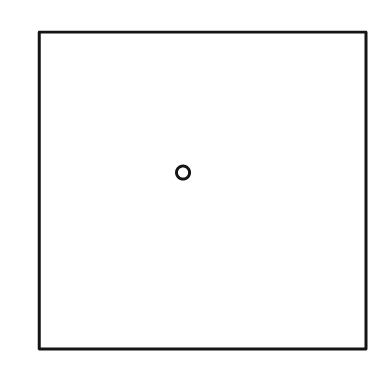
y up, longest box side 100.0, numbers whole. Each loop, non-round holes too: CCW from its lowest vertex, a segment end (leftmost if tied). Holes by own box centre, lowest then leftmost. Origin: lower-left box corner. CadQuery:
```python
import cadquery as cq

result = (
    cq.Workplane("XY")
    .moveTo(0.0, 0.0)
    .lineTo(100.0, 0.0)
    .lineTo(100.0, 97.0)
    .lineTo(0.0, 97.0)
    .close()
    .moveTo(44.0, 54.0)
    .circle(2.0)
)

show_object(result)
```